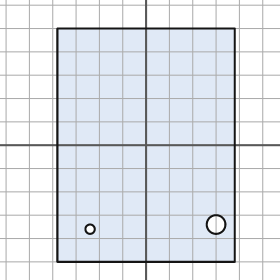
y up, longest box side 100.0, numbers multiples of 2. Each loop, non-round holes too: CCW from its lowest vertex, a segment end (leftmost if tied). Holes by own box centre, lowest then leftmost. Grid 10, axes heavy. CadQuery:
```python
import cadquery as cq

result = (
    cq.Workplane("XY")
    .moveTo(-38.0, -50.0)
    .lineTo(38.0, -50.0)
    .lineTo(38.0, 50.0)
    .lineTo(-38.0, 50.0)
    .close()
    .moveTo(-24.0, -36.0)
    .circle(2.0)
    .moveTo(30.0, -34.0)
    .circle(4.0)
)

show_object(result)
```